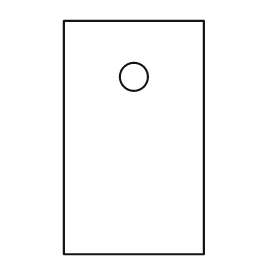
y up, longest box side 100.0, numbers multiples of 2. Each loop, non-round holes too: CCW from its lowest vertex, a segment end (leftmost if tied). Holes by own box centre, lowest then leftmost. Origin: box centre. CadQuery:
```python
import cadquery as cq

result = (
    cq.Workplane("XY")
    .moveTo(-30.0, -50.0)
    .lineTo(30.0, -50.0)
    .lineTo(30.0, 50.0)
    .lineTo(-30.0, 50.0)
    .close()
    .moveTo(0.0, 26.0)
    .circle(6.0)
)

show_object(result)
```